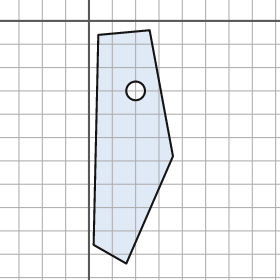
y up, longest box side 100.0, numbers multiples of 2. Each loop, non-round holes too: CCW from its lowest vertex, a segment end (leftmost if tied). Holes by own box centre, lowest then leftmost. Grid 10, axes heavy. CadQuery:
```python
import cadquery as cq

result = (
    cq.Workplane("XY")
    .moveTo(16.0, -104.0)
    .lineTo(36.0, -58.0)
    .lineTo(26.0, -4.0)
    .lineTo(4.0, -6.0)
    .lineTo(2.0, -96.0)
    .close()
    .moveTo(20.0, -30.0)
    .circle(4.0)
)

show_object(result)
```